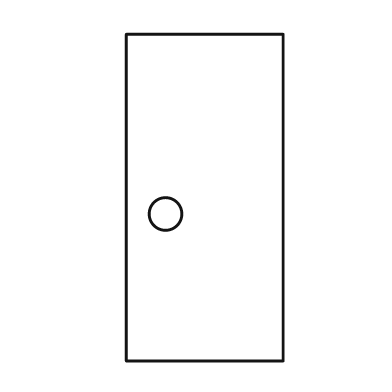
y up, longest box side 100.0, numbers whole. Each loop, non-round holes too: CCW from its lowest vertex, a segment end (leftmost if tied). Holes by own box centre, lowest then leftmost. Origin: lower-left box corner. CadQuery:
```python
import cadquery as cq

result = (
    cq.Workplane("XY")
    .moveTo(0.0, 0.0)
    .lineTo(48.0, 0.0)
    .lineTo(48.0, 100.0)
    .lineTo(0.0, 100.0)
    .close()
    .moveTo(12.0, 45.0)
    .circle(5.0)
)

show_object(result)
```